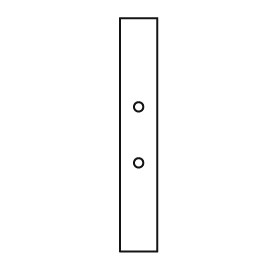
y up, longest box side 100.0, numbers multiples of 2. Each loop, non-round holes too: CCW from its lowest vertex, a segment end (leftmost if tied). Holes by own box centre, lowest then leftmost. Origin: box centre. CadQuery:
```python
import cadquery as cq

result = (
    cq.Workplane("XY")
    .moveTo(-8.0, -50.0)
    .lineTo(8.0, -50.0)
    .lineTo(8.0, 50.0)
    .lineTo(-8.0, 50.0)
    .close()
    .moveTo(0.0, -12.0)
    .circle(2.0)
    .moveTo(0.0, 12.0)
    .circle(2.0)
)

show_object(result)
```